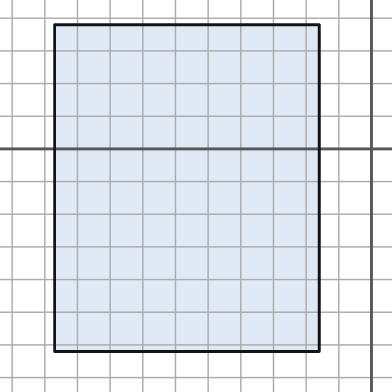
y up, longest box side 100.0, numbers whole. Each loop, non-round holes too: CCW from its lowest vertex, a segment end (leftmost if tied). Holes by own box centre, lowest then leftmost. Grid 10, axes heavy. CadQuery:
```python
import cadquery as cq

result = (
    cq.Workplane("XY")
    .moveTo(-97.0, -62.0)
    .lineTo(-16.0, -62.0)
    .lineTo(-16.0, 38.0)
    .lineTo(-97.0, 38.0)
    .close()
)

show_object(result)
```